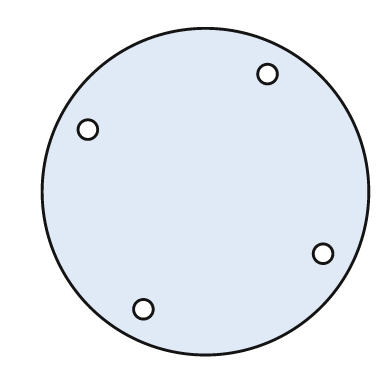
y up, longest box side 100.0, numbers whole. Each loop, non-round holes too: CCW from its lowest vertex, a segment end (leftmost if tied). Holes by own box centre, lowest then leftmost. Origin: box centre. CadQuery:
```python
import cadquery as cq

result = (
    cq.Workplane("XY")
    .moveTo(0.0, 0.0)
    .circle(50.0)
    .moveTo(-19.0, -36.0)
    .circle(3.0)
    .moveTo(36.0, -19.0)
    .circle(3.0)
    .moveTo(-36.0, 19.0)
    .circle(3.0)
    .moveTo(19.0, 36.0)
    .circle(3.0)
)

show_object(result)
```